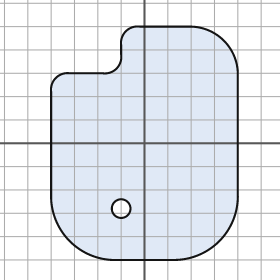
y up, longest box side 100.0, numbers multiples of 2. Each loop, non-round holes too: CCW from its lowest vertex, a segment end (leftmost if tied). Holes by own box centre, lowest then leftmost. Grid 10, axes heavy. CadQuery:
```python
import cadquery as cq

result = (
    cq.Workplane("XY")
    .moveTo(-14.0, -50.0)
    .lineTo(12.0, -50.0)
    .threePointArc((32.0, -42.0), (40.0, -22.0))
    .lineTo(40.0, 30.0)
    .threePointArc((34.0, 44.0), (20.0, 50.0))
    .lineTo(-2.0, 50.0)
    .threePointArc((-8.0, 48.0), (-10.0, 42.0))
    .lineTo(-10.0, 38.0)
    .threePointArc((-12.0, 32.0), (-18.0, 30.0))
    .lineTo(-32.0, 30.0)
    .threePointArc((-38.0, 28.0), (-40.0, 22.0))
    .lineTo(-40.0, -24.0)
    .threePointArc((-32.0, -42.0), (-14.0, -50.0))
    .close()
    .moveTo(-10.0, -28.0)
    .circle(4.0)
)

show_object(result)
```